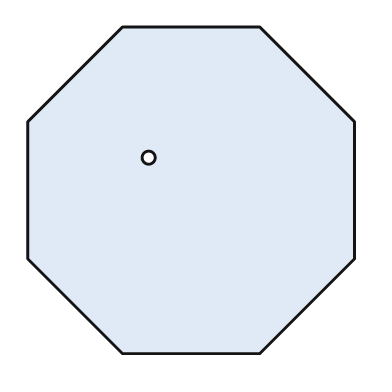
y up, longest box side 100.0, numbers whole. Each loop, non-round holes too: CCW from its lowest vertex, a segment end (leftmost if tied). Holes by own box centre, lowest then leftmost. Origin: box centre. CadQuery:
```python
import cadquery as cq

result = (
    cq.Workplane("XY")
    .moveTo(-21.0, -50.0)
    .lineTo(21.0, -50.0)
    .lineTo(50.0, -21.0)
    .lineTo(50.0, 21.0)
    .lineTo(21.0, 50.0)
    .lineTo(-21.0, 50.0)
    .lineTo(-50.0, 21.0)
    .lineTo(-50.0, -21.0)
    .close()
    .moveTo(-13.0, 10.0)
    .circle(2.0)
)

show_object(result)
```